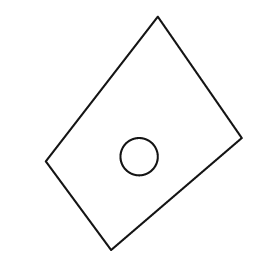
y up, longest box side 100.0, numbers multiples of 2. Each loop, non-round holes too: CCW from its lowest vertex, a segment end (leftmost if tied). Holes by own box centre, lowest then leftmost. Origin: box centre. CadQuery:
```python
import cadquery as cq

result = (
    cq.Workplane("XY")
    .moveTo(-14.0, -50.0)
    .lineTo(42.0, -2.0)
    .lineTo(6.0, 50.0)
    .lineTo(-42.0, -12.0)
    .close()
    .moveTo(-2.0, -10.0)
    .circle(8.0)
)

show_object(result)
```